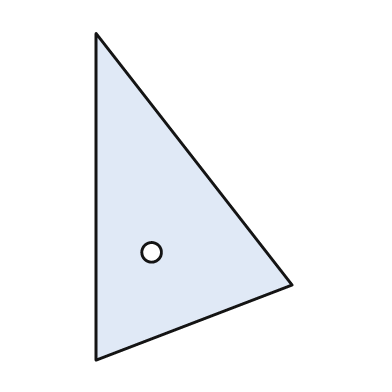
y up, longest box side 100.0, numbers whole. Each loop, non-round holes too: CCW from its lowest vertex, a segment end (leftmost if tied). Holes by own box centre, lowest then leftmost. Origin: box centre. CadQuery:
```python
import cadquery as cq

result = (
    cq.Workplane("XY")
    .moveTo(-30.0, -50.0)
    .lineTo(30.0, -27.0)
    .lineTo(-30.0, 50.0)
    .close()
    .moveTo(-13.0, -17.0)
    .circle(3.0)
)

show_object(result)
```